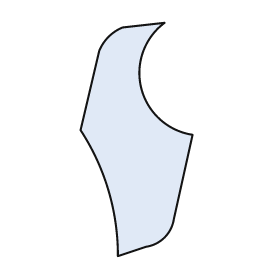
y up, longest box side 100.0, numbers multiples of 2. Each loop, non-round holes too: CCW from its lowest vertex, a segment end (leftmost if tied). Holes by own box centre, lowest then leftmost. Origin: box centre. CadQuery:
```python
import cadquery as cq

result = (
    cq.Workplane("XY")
    .moveTo(-8.0, -50.0)
    .lineTo(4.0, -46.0)
    .threePointArc((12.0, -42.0), (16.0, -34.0))
    .lineTo(24.0, 2.0)
    .threePointArc((2.0, 22.0), (12.0, 50.0))
    .lineTo(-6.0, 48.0)
    .threePointArc((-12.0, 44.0), (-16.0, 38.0))
    .lineTo(-24.0, 4.0)
    .threePointArc((-12.0, -22.0), (-8.0, -50.0))
    .close()
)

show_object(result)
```